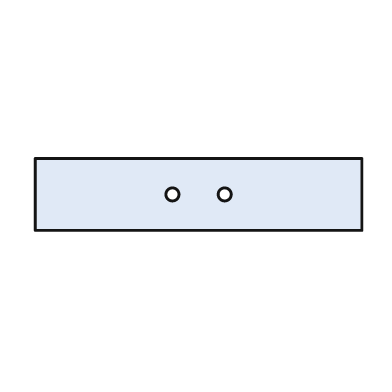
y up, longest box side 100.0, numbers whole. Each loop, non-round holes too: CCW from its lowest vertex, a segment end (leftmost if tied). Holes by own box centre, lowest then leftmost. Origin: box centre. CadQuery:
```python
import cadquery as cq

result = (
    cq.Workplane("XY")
    .moveTo(-50.0, -11.0)
    .lineTo(50.0, -11.0)
    .lineTo(50.0, 11.0)
    .lineTo(-50.0, 11.0)
    .close()
    .moveTo(-8.0, 0.0)
    .circle(2.0)
    .moveTo(8.0, 0.0)
    .circle(2.0)
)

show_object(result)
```